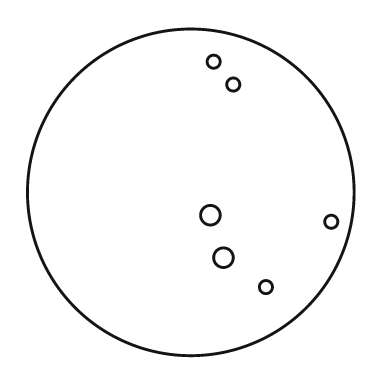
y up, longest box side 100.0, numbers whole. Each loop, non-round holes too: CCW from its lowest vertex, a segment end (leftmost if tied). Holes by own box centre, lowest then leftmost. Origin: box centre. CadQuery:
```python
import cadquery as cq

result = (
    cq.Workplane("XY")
    .moveTo(0.0, 0.0)
    .circle(50.0)
    .moveTo(23.0, -29.0)
    .circle(2.0)
    .moveTo(10.0, -20.0)
    .circle(3.0)
    .moveTo(43.0, -9.0)
    .circle(2.0)
    .moveTo(6.0, -7.0)
    .circle(3.0)
    .moveTo(13.0, 33.0)
    .circle(2.0)
    .moveTo(7.0, 40.0)
    .circle(2.0)
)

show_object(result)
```